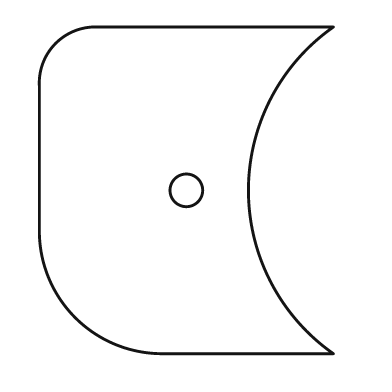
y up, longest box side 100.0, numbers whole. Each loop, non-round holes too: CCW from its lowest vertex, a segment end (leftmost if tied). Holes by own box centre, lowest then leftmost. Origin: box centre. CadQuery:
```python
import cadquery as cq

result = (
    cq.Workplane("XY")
    .moveTo(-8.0, -50.0)
    .lineTo(45.0, -50.0)
    .threePointArc((19.0, 0.0), (45.0, 50.0))
    .lineTo(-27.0, 50.0)
    .threePointArc((-40.0, 45.0), (-45.0, 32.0))
    .lineTo(-45.0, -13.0)
    .threePointArc((-34.0, -39.0), (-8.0, -50.0))
    .close()
    .moveTo(0.0, 0.0)
    .circle(5.0)
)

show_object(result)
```